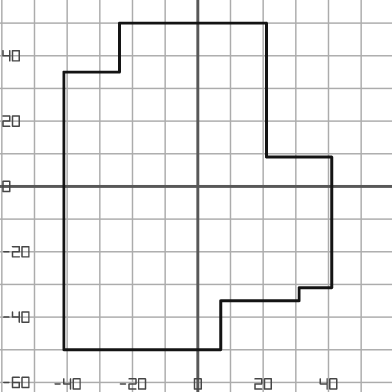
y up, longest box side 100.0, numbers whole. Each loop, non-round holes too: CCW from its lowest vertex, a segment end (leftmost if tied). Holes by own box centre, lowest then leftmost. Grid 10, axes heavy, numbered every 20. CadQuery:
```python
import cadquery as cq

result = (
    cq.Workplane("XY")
    .moveTo(-41.0, -50.0)
    .lineTo(7.0, -50.0)
    .lineTo(7.0, -35.0)
    .lineTo(31.0, -35.0)
    .lineTo(31.0, -31.0)
    .lineTo(41.0, -31.0)
    .lineTo(41.0, 9.0)
    .lineTo(21.0, 9.0)
    .lineTo(21.0, 50.0)
    .lineTo(-24.0, 50.0)
    .lineTo(-24.0, 35.0)
    .lineTo(-41.0, 35.0)
    .close()
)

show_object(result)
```